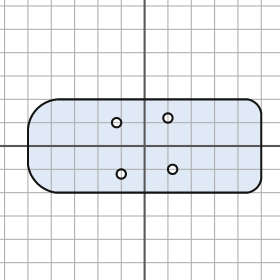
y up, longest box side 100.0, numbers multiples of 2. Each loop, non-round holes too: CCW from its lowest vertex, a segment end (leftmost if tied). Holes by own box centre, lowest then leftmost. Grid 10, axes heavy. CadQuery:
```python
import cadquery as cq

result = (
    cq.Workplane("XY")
    .moveTo(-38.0, -20.0)
    .lineTo(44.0, -20.0)
    .threePointArc((48.0, -18.0), (50.0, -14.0))
    .lineTo(50.0, 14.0)
    .threePointArc((48.0, 18.0), (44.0, 20.0))
    .lineTo(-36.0, 20.0)
    .threePointArc((-46.0, 16.0), (-50.0, 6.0))
    .lineTo(-50.0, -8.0)
    .threePointArc((-46.0, -16.0), (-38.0, -20.0))
    .close()
    .moveTo(-10.0, -12.0)
    .circle(2.0)
    .moveTo(12.0, -10.0)
    .circle(2.0)
    .moveTo(-12.0, 10.0)
    .circle(2.0)
    .moveTo(10.0, 12.0)
    .circle(2.0)
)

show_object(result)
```